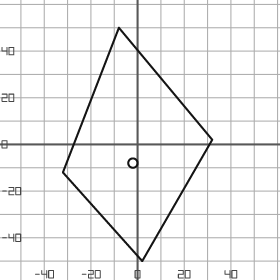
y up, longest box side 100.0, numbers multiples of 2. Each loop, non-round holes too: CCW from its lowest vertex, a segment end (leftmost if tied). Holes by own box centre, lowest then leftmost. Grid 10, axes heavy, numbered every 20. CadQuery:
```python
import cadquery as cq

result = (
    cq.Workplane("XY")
    .moveTo(2.0, -50.0)
    .lineTo(32.0, 2.0)
    .lineTo(-8.0, 50.0)
    .lineTo(-32.0, -12.0)
    .close()
    .moveTo(-2.0, -8.0)
    .circle(2.0)
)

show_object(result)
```